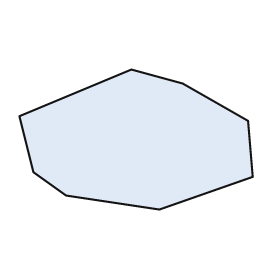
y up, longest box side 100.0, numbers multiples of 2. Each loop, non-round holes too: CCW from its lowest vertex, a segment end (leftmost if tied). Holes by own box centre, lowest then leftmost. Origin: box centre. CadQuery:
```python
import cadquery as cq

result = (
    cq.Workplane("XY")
    .moveTo(10.0, -30.0)
    .lineTo(50.0, -16.0)
    .lineTo(48.0, 8.0)
    .lineTo(20.0, 24.0)
    .lineTo(-2.0, 30.0)
    .lineTo(-50.0, 10.0)
    .lineTo(-44.0, -14.0)
    .lineTo(-30.0, -24.0)
    .close()
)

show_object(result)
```